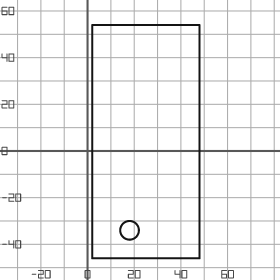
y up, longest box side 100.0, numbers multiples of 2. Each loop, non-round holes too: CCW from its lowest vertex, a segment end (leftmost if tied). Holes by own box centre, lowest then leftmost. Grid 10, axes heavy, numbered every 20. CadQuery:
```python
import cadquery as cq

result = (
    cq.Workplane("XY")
    .moveTo(2.0, -46.0)
    .lineTo(48.0, -46.0)
    .lineTo(48.0, 54.0)
    .lineTo(2.0, 54.0)
    .close()
    .moveTo(18.0, -34.0)
    .circle(4.0)
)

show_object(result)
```